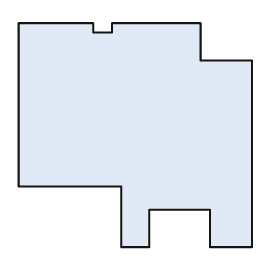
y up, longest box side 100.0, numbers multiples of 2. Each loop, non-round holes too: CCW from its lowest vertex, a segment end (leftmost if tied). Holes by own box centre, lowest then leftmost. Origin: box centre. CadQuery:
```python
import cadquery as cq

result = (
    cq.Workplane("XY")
    .moveTo(-6.0, -48.0)
    .lineTo(6.0, -48.0)
    .lineTo(6.0, -32.0)
    .lineTo(32.0, -32.0)
    .lineTo(32.0, -48.0)
    .lineTo(50.0, -48.0)
    .lineTo(50.0, 32.0)
    .lineTo(28.0, 32.0)
    .lineTo(28.0, 48.0)
    .lineTo(-10.0, 48.0)
    .lineTo(-10.0, 44.0)
    .lineTo(-18.0, 44.0)
    .lineTo(-18.0, 48.0)
    .lineTo(-50.0, 48.0)
    .lineTo(-50.0, -22.0)
    .lineTo(-6.0, -22.0)
    .close()
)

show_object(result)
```